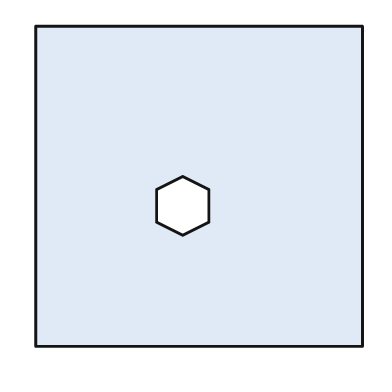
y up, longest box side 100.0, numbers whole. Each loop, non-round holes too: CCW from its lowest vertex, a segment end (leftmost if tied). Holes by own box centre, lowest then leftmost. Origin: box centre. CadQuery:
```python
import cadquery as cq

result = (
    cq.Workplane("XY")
    .moveTo(-50.0, -49.0)
    .lineTo(50.0, -49.0)
    .lineTo(50.0, 49.0)
    .lineTo(-50.0, 49.0)
    .close()
    .moveTo(-5.0, -15.0)
    .lineTo(3.0, -11.0)
    .lineTo(3.0, -1.0)
    .lineTo(-5.0, 3.0)
    .lineTo(-13.0, -1.0)
    .lineTo(-13.0, -11.0)
    .close()
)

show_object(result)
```